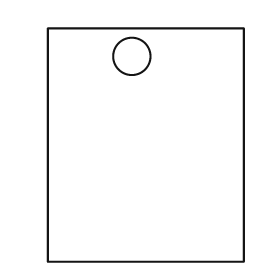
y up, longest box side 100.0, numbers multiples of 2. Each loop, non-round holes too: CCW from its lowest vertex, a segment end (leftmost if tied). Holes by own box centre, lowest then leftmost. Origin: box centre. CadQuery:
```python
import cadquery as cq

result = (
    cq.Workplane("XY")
    .moveTo(-42.0, -50.0)
    .lineTo(42.0, -50.0)
    .lineTo(42.0, 50.0)
    .lineTo(-42.0, 50.0)
    .close()
    .moveTo(-6.0, 38.0)
    .circle(8.0)
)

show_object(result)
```